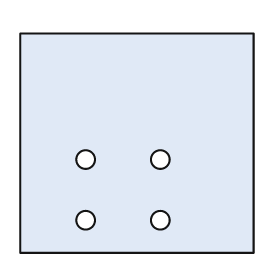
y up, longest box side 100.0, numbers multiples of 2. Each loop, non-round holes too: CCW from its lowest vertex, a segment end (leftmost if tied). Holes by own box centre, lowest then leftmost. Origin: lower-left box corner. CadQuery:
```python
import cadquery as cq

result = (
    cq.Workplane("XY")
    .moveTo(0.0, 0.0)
    .lineTo(100.0, 0.0)
    .lineTo(100.0, 94.0)
    .lineTo(0.0, 94.0)
    .close()
    .moveTo(28.0, 14.0)
    .circle(4.0)
    .moveTo(60.0, 14.0)
    .circle(4.0)
    .moveTo(28.0, 40.0)
    .circle(4.0)
    .moveTo(60.0, 40.0)
    .circle(4.0)
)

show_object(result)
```